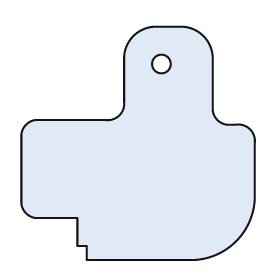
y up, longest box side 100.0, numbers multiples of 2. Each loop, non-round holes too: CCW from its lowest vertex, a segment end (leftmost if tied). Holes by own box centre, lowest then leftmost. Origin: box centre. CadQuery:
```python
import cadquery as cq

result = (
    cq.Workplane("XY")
    .moveTo(-22.0, -50.0)
    .lineTo(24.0, -50.0)
    .threePointArc((42.0, -42.0), (50.0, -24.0))
    .lineTo(50.0, 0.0)
    .threePointArc((48.0, 6.0), (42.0, 8.0))
    .lineTo(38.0, 8.0)
    .threePointArc((34.0, 10.0), (32.0, 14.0))
    .lineTo(32.0, 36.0)
    .threePointArc((28.0, 46.0), (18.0, 50.0))
    .lineTo(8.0, 50.0)
    .threePointArc((-2.0, 46.0), (-6.0, 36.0))
    .lineTo(-6.0, 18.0)
    .threePointArc((-8.0, 12.0), (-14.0, 10.0))
    .lineTo(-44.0, 10.0)
    .threePointArc((-48.0, 8.0), (-50.0, 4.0))
    .lineTo(-50.0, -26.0)
    .threePointArc((-48.0, -30.0), (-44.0, -32.0))
    .lineTo(-26.0, -32.0)
    .lineTo(-26.0, -44.0)
    .lineTo(-22.0, -44.0)
    .close()
    .moveTo(10.0, 34.0)
    .circle(4.0)
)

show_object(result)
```